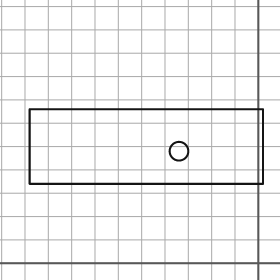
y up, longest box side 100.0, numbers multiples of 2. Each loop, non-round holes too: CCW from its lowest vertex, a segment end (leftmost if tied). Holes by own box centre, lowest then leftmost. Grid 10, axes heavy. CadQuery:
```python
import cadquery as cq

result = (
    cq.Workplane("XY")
    .moveTo(-98.0, 34.0)
    .lineTo(2.0, 34.0)
    .lineTo(2.0, 66.0)
    .lineTo(-98.0, 66.0)
    .close()
    .moveTo(-34.0, 48.0)
    .circle(4.0)
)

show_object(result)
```